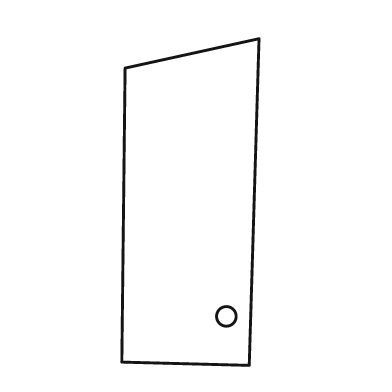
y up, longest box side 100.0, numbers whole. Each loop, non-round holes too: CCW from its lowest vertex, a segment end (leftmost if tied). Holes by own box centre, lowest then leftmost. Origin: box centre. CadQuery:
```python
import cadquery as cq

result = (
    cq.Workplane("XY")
    .moveTo(18.0, -50.0)
    .lineTo(21.0, 50.0)
    .lineTo(-20.0, 41.0)
    .lineTo(-21.0, -49.0)
    .close()
    .moveTo(11.0, -35.0)
    .circle(3.0)
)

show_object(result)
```